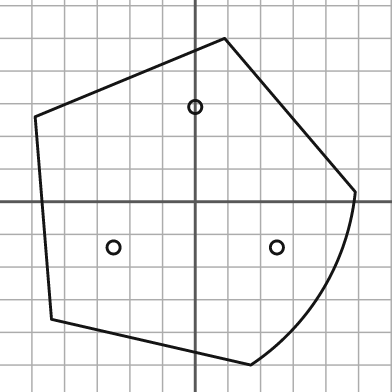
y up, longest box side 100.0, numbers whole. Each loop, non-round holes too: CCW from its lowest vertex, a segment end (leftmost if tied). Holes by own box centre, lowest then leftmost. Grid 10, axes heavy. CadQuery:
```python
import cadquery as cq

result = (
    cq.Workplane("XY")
    .moveTo(17.0, -50.0)
    .threePointArc((39.0, -27.0), (49.0, 3.0))
    .lineTo(9.0, 50.0)
    .lineTo(-49.0, 26.0)
    .lineTo(-44.0, -36.0)
    .close()
    .moveTo(-25.0, -14.0)
    .circle(2.0)
    .moveTo(25.0, -14.0)
    .circle(2.0)
    .moveTo(0.0, 29.0)
    .circle(2.0)
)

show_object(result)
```